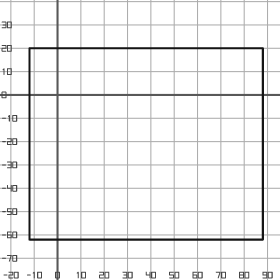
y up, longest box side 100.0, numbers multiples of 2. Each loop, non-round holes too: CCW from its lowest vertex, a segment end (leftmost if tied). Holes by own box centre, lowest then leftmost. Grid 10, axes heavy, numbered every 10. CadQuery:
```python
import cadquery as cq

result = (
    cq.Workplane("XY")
    .moveTo(-12.0, -62.0)
    .lineTo(88.0, -62.0)
    .lineTo(88.0, 20.0)
    .lineTo(-12.0, 20.0)
    .close()
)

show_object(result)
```